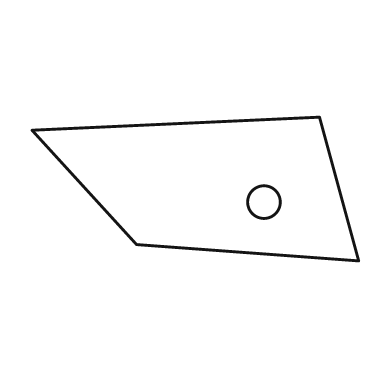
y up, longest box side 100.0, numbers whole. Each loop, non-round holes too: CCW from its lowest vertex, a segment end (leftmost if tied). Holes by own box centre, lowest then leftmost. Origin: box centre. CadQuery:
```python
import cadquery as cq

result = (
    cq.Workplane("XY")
    .moveTo(50.0, -22.0)
    .lineTo(38.0, 22.0)
    .lineTo(-50.0, 18.0)
    .lineTo(-18.0, -17.0)
    .close()
    .moveTo(21.0, -4.0)
    .circle(5.0)
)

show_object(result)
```